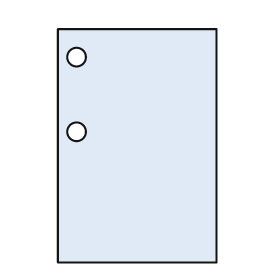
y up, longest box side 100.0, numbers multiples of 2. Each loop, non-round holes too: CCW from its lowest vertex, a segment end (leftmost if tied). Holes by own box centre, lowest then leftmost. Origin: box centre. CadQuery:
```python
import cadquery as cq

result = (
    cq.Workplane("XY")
    .moveTo(-34.0, -50.0)
    .lineTo(34.0, -50.0)
    .lineTo(34.0, 50.0)
    .lineTo(-34.0, 50.0)
    .close()
    .moveTo(-26.0, 6.0)
    .circle(4.0)
    .moveTo(-26.0, 38.0)
    .circle(4.0)
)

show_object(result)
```